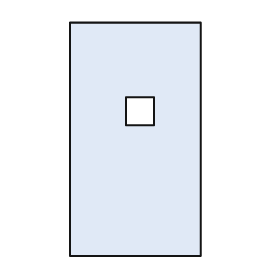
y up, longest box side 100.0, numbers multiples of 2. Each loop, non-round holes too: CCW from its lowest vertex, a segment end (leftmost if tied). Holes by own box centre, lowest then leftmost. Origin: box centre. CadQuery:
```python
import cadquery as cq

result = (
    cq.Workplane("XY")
    .moveTo(-28.0, -50.0)
    .lineTo(28.0, -50.0)
    .lineTo(28.0, 50.0)
    .lineTo(-28.0, 50.0)
    .close()
    .moveTo(-4.0, 6.0)
    .lineTo(8.0, 6.0)
    .lineTo(8.0, 18.0)
    .lineTo(-4.0, 18.0)
    .close()
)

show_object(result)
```